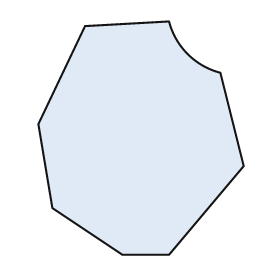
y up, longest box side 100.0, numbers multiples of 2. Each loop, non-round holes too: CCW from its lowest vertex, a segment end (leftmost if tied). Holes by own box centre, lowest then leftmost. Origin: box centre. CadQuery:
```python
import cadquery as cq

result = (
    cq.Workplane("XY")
    .moveTo(-8.0, -50.0)
    .lineTo(12.0, -50.0)
    .lineTo(44.0, -12.0)
    .lineTo(34.0, 28.0)
    .threePointArc((20.0, 36.0), (12.0, 50.0))
    .lineTo(-24.0, 48.0)
    .lineTo(-44.0, 6.0)
    .lineTo(-38.0, -30.0)
    .close()
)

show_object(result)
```